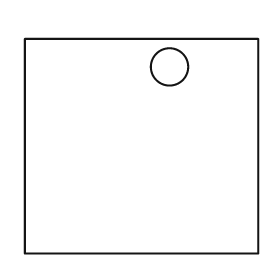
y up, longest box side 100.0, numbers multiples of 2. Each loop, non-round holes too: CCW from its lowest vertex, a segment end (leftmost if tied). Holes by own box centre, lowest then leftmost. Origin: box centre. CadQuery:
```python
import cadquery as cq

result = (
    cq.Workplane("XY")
    .moveTo(-50.0, -46.0)
    .lineTo(50.0, -46.0)
    .lineTo(50.0, 46.0)
    .lineTo(-50.0, 46.0)
    .close()
    .moveTo(12.0, 34.0)
    .circle(8.0)
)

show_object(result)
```